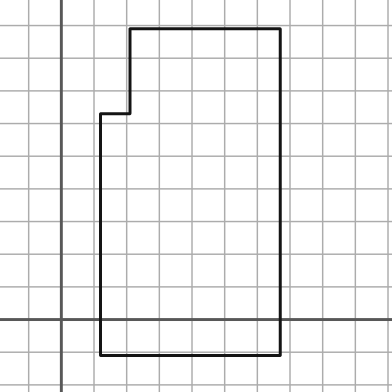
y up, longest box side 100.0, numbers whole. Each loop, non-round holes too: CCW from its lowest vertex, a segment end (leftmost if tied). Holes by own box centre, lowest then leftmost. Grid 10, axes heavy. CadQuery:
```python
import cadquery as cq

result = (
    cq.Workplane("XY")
    .moveTo(12.0, -11.0)
    .lineTo(67.0, -11.0)
    .lineTo(67.0, 89.0)
    .lineTo(21.0, 89.0)
    .lineTo(21.0, 63.0)
    .lineTo(12.0, 63.0)
    .close()
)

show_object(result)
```